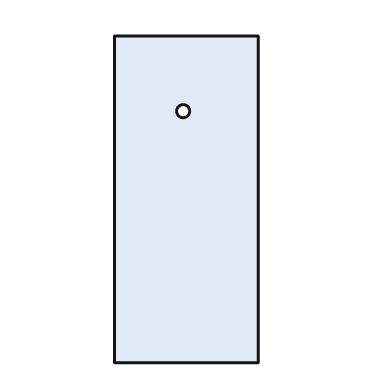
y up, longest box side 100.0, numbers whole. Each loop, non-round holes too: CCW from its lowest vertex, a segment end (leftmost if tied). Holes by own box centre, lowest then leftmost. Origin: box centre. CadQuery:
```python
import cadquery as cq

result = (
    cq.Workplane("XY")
    .moveTo(-22.0, -50.0)
    .lineTo(22.0, -50.0)
    .lineTo(22.0, 50.0)
    .lineTo(-22.0, 50.0)
    .close()
    .moveTo(-1.0, 27.0)
    .circle(2.0)
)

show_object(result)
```